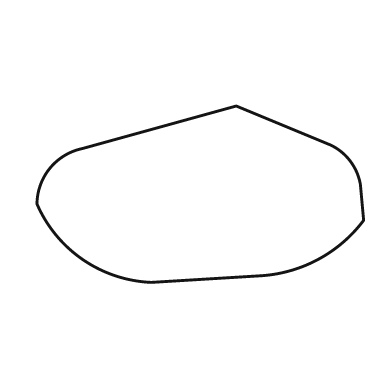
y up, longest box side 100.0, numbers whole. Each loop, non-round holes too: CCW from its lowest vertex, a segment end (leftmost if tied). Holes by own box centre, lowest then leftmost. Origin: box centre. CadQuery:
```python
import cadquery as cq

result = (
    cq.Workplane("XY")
    .moveTo(-15.0, -27.0)
    .lineTo(18.0, -25.0)
    .threePointArc((36.0, -20.0), (50.0, -8.0))
    .lineTo(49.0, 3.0)
    .threePointArc((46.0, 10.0), (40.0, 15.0))
    .lineTo(11.0, 27.0)
    .lineTo(-36.0, 14.0)
    .threePointArc((-46.0, 8.0), (-50.0, -3.0))
    .threePointArc((-36.0, -20.0), (-15.0, -27.0))
    .close()
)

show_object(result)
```